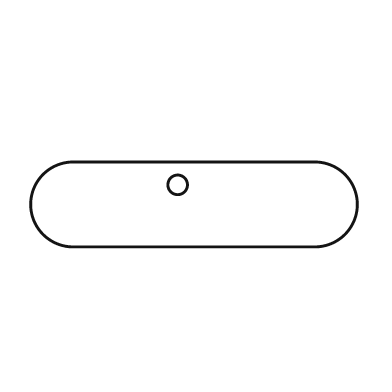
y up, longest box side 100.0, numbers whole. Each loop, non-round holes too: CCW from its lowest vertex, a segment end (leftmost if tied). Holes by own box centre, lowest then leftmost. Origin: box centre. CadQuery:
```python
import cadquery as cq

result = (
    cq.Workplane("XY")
    .moveTo(-37.0, -13.0)
    .lineTo(37.0, -13.0)
    .threePointArc((50.0, 0.0), (37.0, 13.0))
    .lineTo(-37.0, 13.0)
    .threePointArc((-50.0, 0.0), (-37.0, -13.0))
    .close()
    .moveTo(-5.0, 6.0)
    .circle(3.0)
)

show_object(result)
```